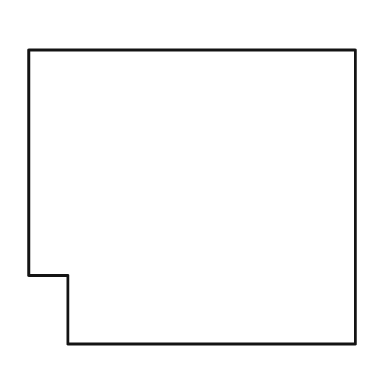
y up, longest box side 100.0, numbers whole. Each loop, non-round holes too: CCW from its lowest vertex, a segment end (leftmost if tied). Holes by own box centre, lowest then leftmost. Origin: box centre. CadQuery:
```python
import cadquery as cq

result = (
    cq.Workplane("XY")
    .moveTo(-38.0, -45.0)
    .lineTo(50.0, -45.0)
    .lineTo(50.0, 45.0)
    .lineTo(-50.0, 45.0)
    .lineTo(-50.0, -24.0)
    .lineTo(-38.0, -24.0)
    .close()
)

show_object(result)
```